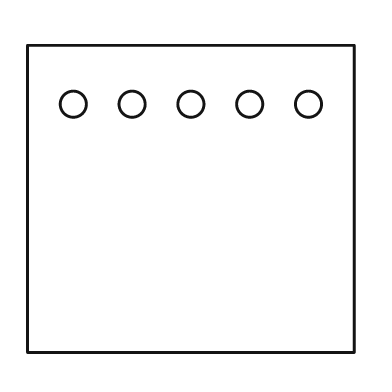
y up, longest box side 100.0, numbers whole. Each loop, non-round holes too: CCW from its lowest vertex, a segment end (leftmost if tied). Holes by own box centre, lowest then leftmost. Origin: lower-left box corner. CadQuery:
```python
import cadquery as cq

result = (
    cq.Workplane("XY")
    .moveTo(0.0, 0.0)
    .lineTo(100.0, 0.0)
    .lineTo(100.0, 94.0)
    .lineTo(0.0, 94.0)
    .close()
    .moveTo(14.0, 76.0)
    .circle(4.0)
    .moveTo(32.0, 76.0)
    .circle(4.0)
    .moveTo(50.0, 76.0)
    .circle(4.0)
    .moveTo(68.0, 76.0)
    .circle(4.0)
    .moveTo(86.0, 76.0)
    .circle(4.0)
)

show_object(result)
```